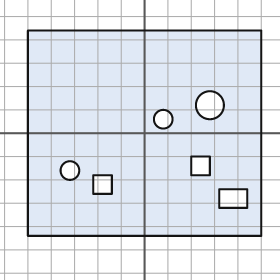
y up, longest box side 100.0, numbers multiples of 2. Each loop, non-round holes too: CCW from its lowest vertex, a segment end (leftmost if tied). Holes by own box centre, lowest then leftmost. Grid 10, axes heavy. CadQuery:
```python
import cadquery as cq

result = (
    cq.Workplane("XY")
    .moveTo(-50.0, -44.0)
    .lineTo(50.0, -44.0)
    .lineTo(50.0, 44.0)
    .lineTo(-50.0, 44.0)
    .close()
    .moveTo(32.0, -32.0)
    .lineTo(44.0, -32.0)
    .lineTo(44.0, -24.0)
    .lineTo(32.0, -24.0)
    .close()
    .moveTo(-22.0, -26.0)
    .lineTo(-14.0, -26.0)
    .lineTo(-14.0, -18.0)
    .lineTo(-22.0, -18.0)
    .close()
    .moveTo(-32.0, -16.0)
    .circle(4.0)
    .moveTo(20.0, -18.0)
    .lineTo(28.0, -18.0)
    .lineTo(28.0, -10.0)
    .lineTo(20.0, -10.0)
    .close()
    .moveTo(8.0, 6.0)
    .circle(4.0)
    .moveTo(28.0, 12.0)
    .circle(6.0)
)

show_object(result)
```